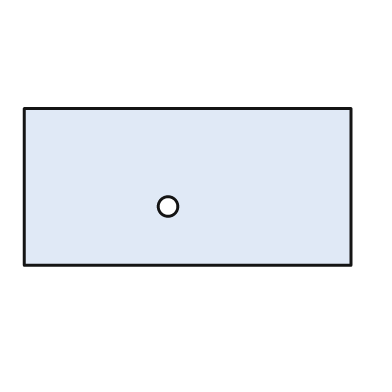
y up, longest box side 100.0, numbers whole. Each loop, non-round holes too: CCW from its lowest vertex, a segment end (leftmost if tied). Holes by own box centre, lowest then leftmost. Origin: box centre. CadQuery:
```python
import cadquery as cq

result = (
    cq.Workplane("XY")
    .moveTo(-50.0, -24.0)
    .lineTo(50.0, -24.0)
    .lineTo(50.0, 24.0)
    .lineTo(-50.0, 24.0)
    .close()
    .moveTo(-6.0, -6.0)
    .circle(3.0)
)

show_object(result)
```